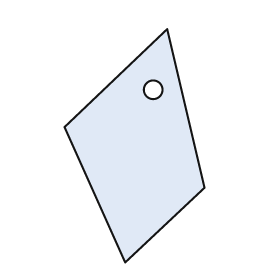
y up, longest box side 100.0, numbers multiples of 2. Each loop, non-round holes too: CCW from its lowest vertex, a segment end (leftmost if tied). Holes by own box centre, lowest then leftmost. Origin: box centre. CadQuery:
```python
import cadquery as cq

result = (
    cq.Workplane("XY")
    .moveTo(-4.0, -50.0)
    .lineTo(30.0, -18.0)
    .lineTo(14.0, 50.0)
    .lineTo(-30.0, 8.0)
    .close()
    .moveTo(8.0, 24.0)
    .circle(4.0)
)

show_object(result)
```